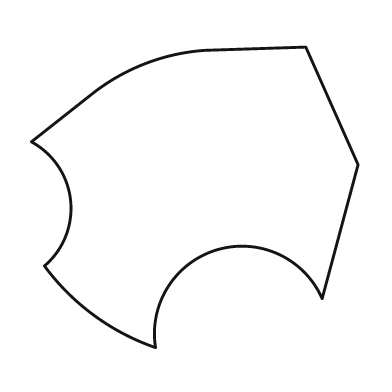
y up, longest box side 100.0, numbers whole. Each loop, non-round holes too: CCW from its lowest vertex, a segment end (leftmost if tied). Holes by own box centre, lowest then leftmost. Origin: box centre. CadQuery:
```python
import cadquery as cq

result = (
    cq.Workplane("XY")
    .moveTo(-12.0, -46.0)
    .threePointArc((7.0, -16.0), (39.0, -31.0))
    .lineTo(50.0, 10.0)
    .lineTo(34.0, 46.0)
    .lineTo(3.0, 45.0)
    .threePointArc((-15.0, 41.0), (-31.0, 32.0))
    .lineTo(-50.0, 17.0)
    .threePointArc((-38.0, -1.0), (-46.0, -21.0))
    .threePointArc((-31.0, -36.0), (-12.0, -46.0))
    .close()
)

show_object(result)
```